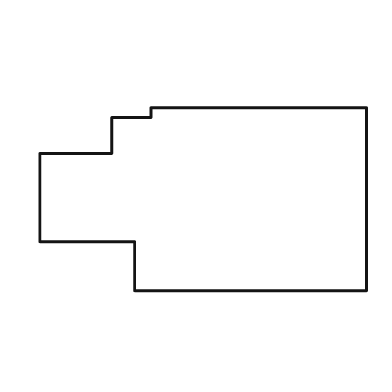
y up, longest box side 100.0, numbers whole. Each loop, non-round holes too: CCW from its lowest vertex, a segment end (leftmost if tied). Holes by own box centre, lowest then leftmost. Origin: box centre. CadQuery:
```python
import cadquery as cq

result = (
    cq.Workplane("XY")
    .moveTo(-21.0, -28.0)
    .lineTo(50.0, -28.0)
    .lineTo(50.0, 28.0)
    .lineTo(-16.0, 28.0)
    .lineTo(-16.0, 25.0)
    .lineTo(-28.0, 25.0)
    .lineTo(-28.0, 14.0)
    .lineTo(-50.0, 14.0)
    .lineTo(-50.0, -13.0)
    .lineTo(-21.0, -13.0)
    .close()
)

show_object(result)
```